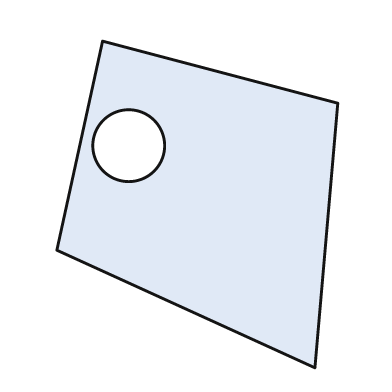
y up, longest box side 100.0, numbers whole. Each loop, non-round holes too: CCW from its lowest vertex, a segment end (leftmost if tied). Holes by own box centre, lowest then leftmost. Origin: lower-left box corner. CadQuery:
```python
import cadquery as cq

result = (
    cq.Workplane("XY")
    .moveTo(79.0, 0.0)
    .lineTo(86.0, 81.0)
    .lineTo(14.0, 100.0)
    .lineTo(0.0, 36.0)
    .close()
    .moveTo(22.0, 68.0)
    .circle(11.0)
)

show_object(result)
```